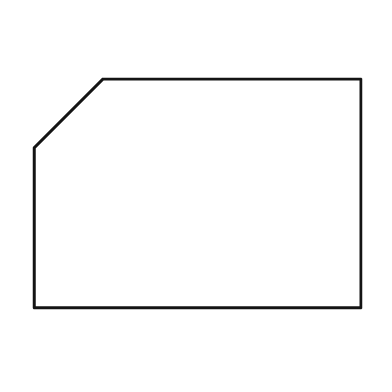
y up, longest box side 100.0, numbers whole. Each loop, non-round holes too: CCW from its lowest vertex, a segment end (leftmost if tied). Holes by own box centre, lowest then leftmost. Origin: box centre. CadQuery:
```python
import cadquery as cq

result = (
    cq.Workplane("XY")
    .moveTo(-50.0, -35.0)
    .lineTo(50.0, -35.0)
    .lineTo(50.0, 35.0)
    .lineTo(-29.0, 35.0)
    .lineTo(-50.0, 14.0)
    .close()
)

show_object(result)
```